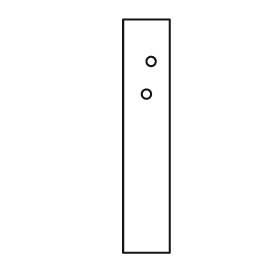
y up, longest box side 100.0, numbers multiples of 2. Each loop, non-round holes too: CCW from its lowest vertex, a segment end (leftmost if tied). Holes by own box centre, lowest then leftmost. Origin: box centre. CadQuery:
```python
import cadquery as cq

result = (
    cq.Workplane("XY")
    .moveTo(-10.0, -50.0)
    .lineTo(10.0, -50.0)
    .lineTo(10.0, 50.0)
    .lineTo(-10.0, 50.0)
    .close()
    .moveTo(0.0, 18.0)
    .circle(2.0)
    .moveTo(2.0, 32.0)
    .circle(2.0)
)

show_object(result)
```